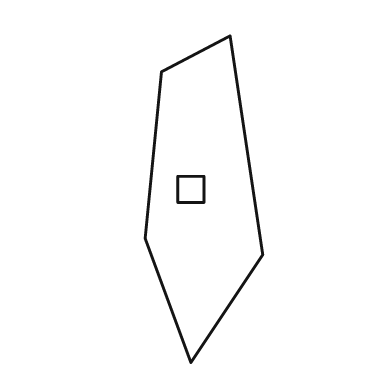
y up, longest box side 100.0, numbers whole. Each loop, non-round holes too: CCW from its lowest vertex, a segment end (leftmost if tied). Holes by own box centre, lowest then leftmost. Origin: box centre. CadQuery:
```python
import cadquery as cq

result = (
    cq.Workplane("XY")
    .moveTo(-4.0, -50.0)
    .lineTo(18.0, -17.0)
    .lineTo(8.0, 50.0)
    .lineTo(-13.0, 39.0)
    .lineTo(-18.0, -12.0)
    .close()
    .moveTo(-8.0, -1.0)
    .lineTo(0.0, -1.0)
    .lineTo(0.0, 7.0)
    .lineTo(-8.0, 7.0)
    .close()
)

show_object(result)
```